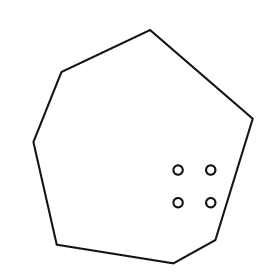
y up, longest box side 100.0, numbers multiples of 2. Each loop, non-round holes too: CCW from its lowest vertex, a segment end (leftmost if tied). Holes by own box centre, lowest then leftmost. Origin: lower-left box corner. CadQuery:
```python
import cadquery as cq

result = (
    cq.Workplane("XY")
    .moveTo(60.0, 0.0)
    .lineTo(78.0, 10.0)
    .lineTo(94.0, 62.0)
    .lineTo(50.0, 100.0)
    .lineTo(12.0, 82.0)
    .lineTo(0.0, 52.0)
    .lineTo(10.0, 8.0)
    .close()
    .moveTo(62.0, 26.0)
    .circle(2.0)
    .moveTo(76.0, 26.0)
    .circle(2.0)
    .moveTo(62.0, 40.0)
    .circle(2.0)
    .moveTo(76.0, 40.0)
    .circle(2.0)
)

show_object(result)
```